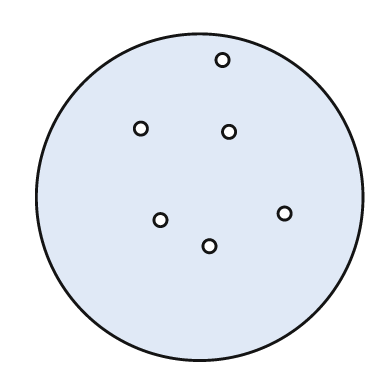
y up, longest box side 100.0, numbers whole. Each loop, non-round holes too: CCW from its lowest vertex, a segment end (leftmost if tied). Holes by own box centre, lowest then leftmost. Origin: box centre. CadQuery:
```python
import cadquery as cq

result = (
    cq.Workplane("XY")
    .moveTo(0.0, 0.0)
    .circle(50.0)
    .moveTo(3.0, -15.0)
    .circle(2.0)
    .moveTo(-12.0, -7.0)
    .circle(2.0)
    .moveTo(26.0, -5.0)
    .circle(2.0)
    .moveTo(9.0, 20.0)
    .circle(2.0)
    .moveTo(-18.0, 21.0)
    .circle(2.0)
    .moveTo(7.0, 42.0)
    .circle(2.0)
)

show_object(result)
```